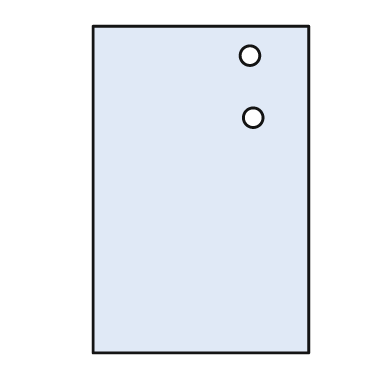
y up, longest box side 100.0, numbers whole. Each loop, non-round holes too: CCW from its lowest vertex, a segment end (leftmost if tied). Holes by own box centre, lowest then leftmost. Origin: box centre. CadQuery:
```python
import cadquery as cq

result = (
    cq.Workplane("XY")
    .moveTo(-33.0, -50.0)
    .lineTo(33.0, -50.0)
    .lineTo(33.0, 50.0)
    .lineTo(-33.0, 50.0)
    .close()
    .moveTo(16.0, 22.0)
    .circle(3.0)
    .moveTo(15.0, 41.0)
    .circle(3.0)
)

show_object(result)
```